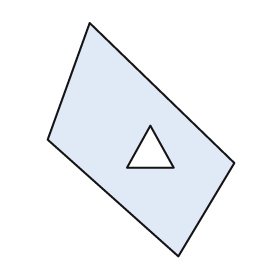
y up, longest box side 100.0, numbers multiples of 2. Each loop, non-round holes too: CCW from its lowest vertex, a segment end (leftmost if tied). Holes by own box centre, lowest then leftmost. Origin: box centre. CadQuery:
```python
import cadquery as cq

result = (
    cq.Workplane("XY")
    .moveTo(16.0, -50.0)
    .lineTo(40.0, -10.0)
    .lineTo(-22.0, 50.0)
    .lineTo(-40.0, 0.0)
    .close()
    .moveTo(-6.0, -12.0)
    .lineTo(14.0, -12.0)
    .lineTo(4.0, 6.0)
    .close()
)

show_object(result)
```